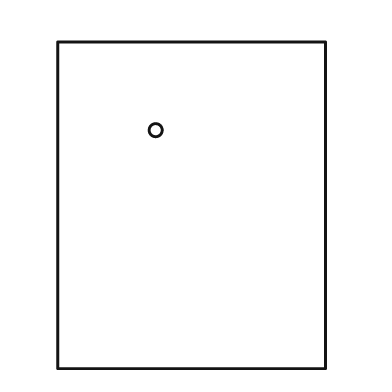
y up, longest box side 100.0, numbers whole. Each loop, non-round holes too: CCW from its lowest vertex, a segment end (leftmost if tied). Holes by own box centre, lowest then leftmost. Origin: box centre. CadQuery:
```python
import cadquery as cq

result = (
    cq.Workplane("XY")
    .moveTo(-41.0, -50.0)
    .lineTo(41.0, -50.0)
    .lineTo(41.0, 50.0)
    .lineTo(-41.0, 50.0)
    .close()
    .moveTo(-11.0, 23.0)
    .circle(2.0)
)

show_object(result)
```